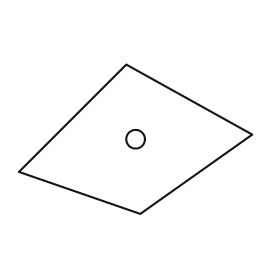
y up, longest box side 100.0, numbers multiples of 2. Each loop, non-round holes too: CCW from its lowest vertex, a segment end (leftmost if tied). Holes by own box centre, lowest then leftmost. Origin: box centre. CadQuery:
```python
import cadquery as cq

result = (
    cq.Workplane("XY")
    .moveTo(2.0, -32.0)
    .lineTo(50.0, 2.0)
    .lineTo(-4.0, 32.0)
    .lineTo(-50.0, -14.0)
    .close()
    .moveTo(0.0, 0.0)
    .circle(4.0)
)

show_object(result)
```